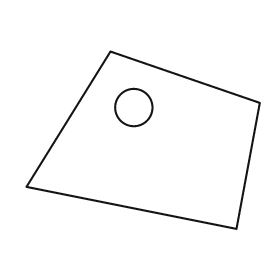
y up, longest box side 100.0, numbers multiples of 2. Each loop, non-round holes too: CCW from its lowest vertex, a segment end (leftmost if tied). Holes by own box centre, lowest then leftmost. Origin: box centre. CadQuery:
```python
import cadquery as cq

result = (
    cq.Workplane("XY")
    .moveTo(40.0, -38.0)
    .lineTo(50.0, 16.0)
    .lineTo(-14.0, 38.0)
    .lineTo(-50.0, -20.0)
    .close()
    .moveTo(-4.0, 14.0)
    .circle(8.0)
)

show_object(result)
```